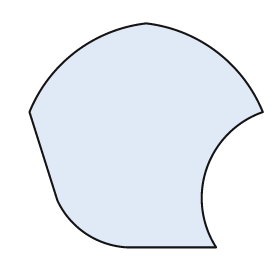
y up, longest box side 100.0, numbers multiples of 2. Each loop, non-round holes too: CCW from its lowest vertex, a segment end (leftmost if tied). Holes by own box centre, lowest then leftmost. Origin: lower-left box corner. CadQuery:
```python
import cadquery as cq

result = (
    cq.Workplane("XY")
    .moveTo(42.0, 0.0)
    .lineTo(80.0, 0.0)
    .threePointArc((76.0, 34.0), (100.0, 58.0))
    .threePointArc((80.0, 84.0), (50.0, 96.0))
    .threePointArc((20.0, 84.0), (0.0, 58.0))
    .lineTo(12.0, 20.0)
    .threePointArc((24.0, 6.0), (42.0, 0.0))
    .close()
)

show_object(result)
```